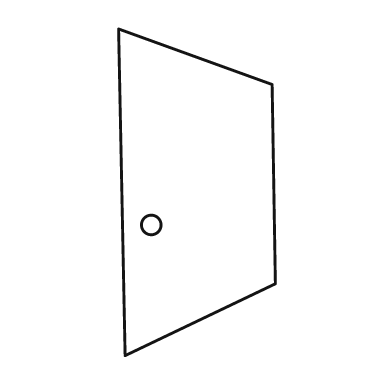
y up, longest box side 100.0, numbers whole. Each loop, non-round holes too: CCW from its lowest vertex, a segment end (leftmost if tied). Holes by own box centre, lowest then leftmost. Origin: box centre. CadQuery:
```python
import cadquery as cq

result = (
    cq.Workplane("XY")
    .moveTo(-22.0, -50.0)
    .lineTo(24.0, -28.0)
    .lineTo(23.0, 33.0)
    .lineTo(-24.0, 50.0)
    .close()
    .moveTo(-14.0, -10.0)
    .circle(3.0)
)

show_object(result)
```